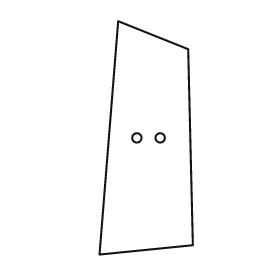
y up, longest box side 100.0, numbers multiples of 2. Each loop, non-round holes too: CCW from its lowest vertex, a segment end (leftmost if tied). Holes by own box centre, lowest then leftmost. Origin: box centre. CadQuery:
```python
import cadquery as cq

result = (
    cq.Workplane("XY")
    .moveTo(-20.0, -50.0)
    .lineTo(20.0, -46.0)
    .lineTo(18.0, 38.0)
    .lineTo(-12.0, 50.0)
    .close()
    .moveTo(-4.0, 0.0)
    .circle(2.0)
    .moveTo(6.0, 0.0)
    .circle(2.0)
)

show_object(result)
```